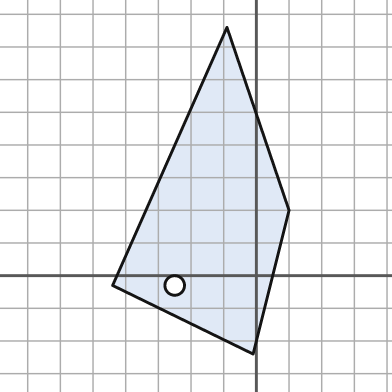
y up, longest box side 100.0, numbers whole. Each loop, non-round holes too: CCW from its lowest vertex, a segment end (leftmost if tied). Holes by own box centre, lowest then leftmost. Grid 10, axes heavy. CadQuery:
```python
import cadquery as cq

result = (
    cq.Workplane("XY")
    .moveTo(-1.0, -24.0)
    .lineTo(10.0, 20.0)
    .lineTo(-9.0, 76.0)
    .lineTo(-44.0, -3.0)
    .close()
    .moveTo(-25.0, -3.0)
    .circle(3.0)
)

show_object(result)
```